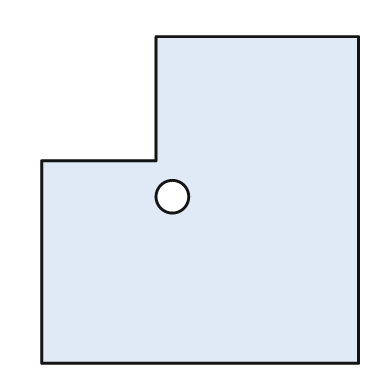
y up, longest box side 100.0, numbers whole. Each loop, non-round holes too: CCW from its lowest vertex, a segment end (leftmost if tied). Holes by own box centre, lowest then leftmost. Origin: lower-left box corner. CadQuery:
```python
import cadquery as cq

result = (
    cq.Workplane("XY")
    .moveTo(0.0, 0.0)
    .lineTo(97.0, 0.0)
    .lineTo(97.0, 100.0)
    .lineTo(35.0, 100.0)
    .lineTo(35.0, 62.0)
    .lineTo(0.0, 62.0)
    .close()
    .moveTo(40.0, 51.0)
    .circle(5.0)
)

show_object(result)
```